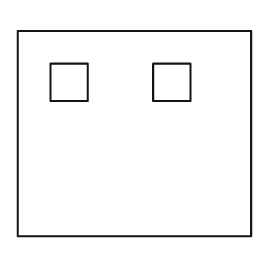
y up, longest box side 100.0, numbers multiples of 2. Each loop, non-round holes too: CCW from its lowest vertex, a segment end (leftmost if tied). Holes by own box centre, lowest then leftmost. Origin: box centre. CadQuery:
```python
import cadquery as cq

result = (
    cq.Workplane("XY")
    .moveTo(-50.0, -44.0)
    .lineTo(50.0, -44.0)
    .lineTo(50.0, 44.0)
    .lineTo(-50.0, 44.0)
    .close()
    .moveTo(-36.0, 14.0)
    .lineTo(-20.0, 14.0)
    .lineTo(-20.0, 30.0)
    .lineTo(-36.0, 30.0)
    .close()
    .moveTo(8.0, 14.0)
    .lineTo(24.0, 14.0)
    .lineTo(24.0, 30.0)
    .lineTo(8.0, 30.0)
    .close()
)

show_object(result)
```